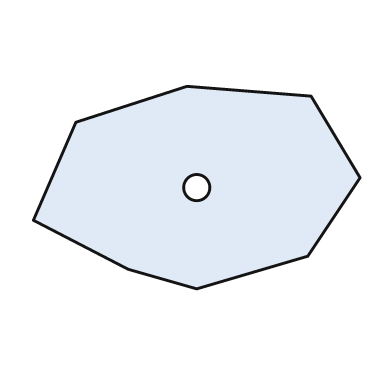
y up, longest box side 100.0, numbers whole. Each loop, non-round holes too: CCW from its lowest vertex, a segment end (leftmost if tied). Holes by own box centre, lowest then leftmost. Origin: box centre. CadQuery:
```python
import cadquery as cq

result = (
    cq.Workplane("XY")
    .moveTo(0.0, -31.0)
    .lineTo(34.0, -21.0)
    .lineTo(50.0, 3.0)
    .lineTo(35.0, 28.0)
    .lineTo(-3.0, 31.0)
    .lineTo(-37.0, 20.0)
    .lineTo(-50.0, -10.0)
    .lineTo(-21.0, -25.0)
    .close()
    .moveTo(0.0, 0.0)
    .circle(4.0)
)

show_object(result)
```